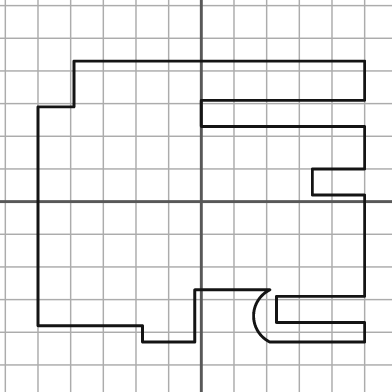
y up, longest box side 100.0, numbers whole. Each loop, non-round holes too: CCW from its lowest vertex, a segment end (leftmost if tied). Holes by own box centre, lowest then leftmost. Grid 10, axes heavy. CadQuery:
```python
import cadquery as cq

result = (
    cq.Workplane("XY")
    .moveTo(-18.0, -43.0)
    .lineTo(-2.0, -43.0)
    .lineTo(-2.0, -27.0)
    .lineTo(21.0, -27.0)
    .threePointArc((16.0, -35.0), (21.0, -43.0))
    .lineTo(50.0, -43.0)
    .lineTo(50.0, -37.0)
    .lineTo(23.0, -37.0)
    .lineTo(23.0, -29.0)
    .lineTo(50.0, -29.0)
    .lineTo(50.0, 2.0)
    .lineTo(34.0, 2.0)
    .lineTo(34.0, 10.0)
    .lineTo(50.0, 10.0)
    .lineTo(50.0, 23.0)
    .lineTo(0.0, 23.0)
    .lineTo(0.0, 31.0)
    .lineTo(50.0, 31.0)
    .lineTo(50.0, 43.0)
    .lineTo(-39.0, 43.0)
    .lineTo(-39.0, 29.0)
    .lineTo(-50.0, 29.0)
    .lineTo(-50.0, -38.0)
    .lineTo(-18.0, -38.0)
    .close()
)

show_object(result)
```